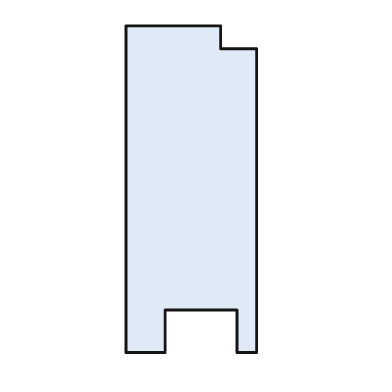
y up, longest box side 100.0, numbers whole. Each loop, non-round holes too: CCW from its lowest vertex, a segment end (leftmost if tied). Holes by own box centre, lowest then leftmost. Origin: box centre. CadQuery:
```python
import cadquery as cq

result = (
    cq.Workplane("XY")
    .moveTo(-20.0, -50.0)
    .lineTo(-8.0, -50.0)
    .lineTo(-8.0, -37.0)
    .lineTo(14.0, -37.0)
    .lineTo(14.0, -50.0)
    .lineTo(20.0, -50.0)
    .lineTo(20.0, 43.0)
    .lineTo(9.0, 43.0)
    .lineTo(9.0, 50.0)
    .lineTo(-20.0, 50.0)
    .close()
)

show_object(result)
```